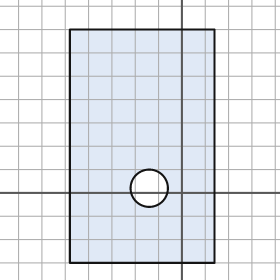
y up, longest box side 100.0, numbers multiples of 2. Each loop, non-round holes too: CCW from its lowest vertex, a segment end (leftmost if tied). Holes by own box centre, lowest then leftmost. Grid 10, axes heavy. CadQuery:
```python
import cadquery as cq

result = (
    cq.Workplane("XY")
    .moveTo(-48.0, -30.0)
    .lineTo(14.0, -30.0)
    .lineTo(14.0, 70.0)
    .lineTo(-48.0, 70.0)
    .close()
    .moveTo(-14.0, 2.0)
    .circle(8.0)
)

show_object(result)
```